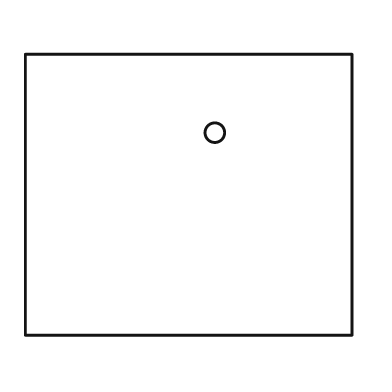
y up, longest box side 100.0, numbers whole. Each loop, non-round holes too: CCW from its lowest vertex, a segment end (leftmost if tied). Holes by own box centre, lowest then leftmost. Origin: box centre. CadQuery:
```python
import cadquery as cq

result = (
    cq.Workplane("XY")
    .moveTo(-50.0, -43.0)
    .lineTo(50.0, -43.0)
    .lineTo(50.0, 43.0)
    .lineTo(-50.0, 43.0)
    .close()
    .moveTo(8.0, 19.0)
    .circle(3.0)
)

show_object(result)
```